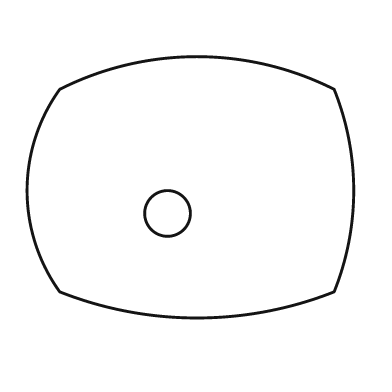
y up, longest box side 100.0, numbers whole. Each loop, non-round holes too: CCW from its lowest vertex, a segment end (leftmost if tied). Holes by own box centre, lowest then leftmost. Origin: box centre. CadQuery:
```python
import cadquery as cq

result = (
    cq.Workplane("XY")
    .moveTo(-40.0, -32.0)
    .threePointArc((2.0, -40.0), (44.0, -32.0))
    .threePointArc((50.0, -1.0), (44.0, 30.0))
    .threePointArc((2.0, 40.0), (-40.0, 30.0))
    .threePointArc((-50.0, -1.0), (-40.0, -32.0))
    .close()
    .moveTo(-7.0, -8.0)
    .circle(7.0)
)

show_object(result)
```